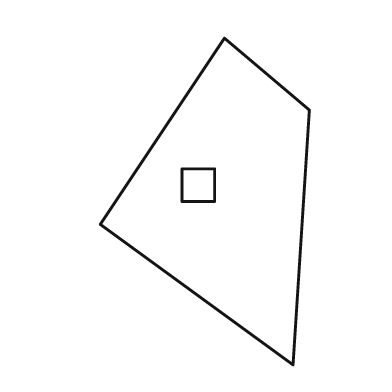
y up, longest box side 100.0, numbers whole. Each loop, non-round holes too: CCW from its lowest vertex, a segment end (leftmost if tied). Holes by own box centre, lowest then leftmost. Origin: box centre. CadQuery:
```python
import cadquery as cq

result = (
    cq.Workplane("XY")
    .moveTo(27.0, -50.0)
    .lineTo(32.0, 28.0)
    .lineTo(6.0, 50.0)
    .lineTo(-32.0, -7.0)
    .close()
    .moveTo(-7.0, 0.0)
    .lineTo(3.0, 0.0)
    .lineTo(3.0, 10.0)
    .lineTo(-7.0, 10.0)
    .close()
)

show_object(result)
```